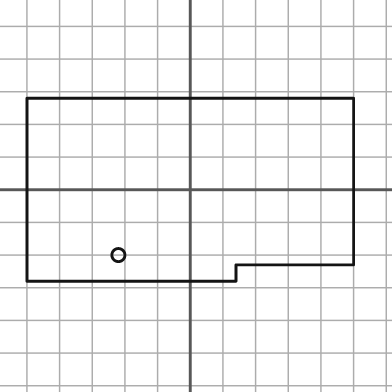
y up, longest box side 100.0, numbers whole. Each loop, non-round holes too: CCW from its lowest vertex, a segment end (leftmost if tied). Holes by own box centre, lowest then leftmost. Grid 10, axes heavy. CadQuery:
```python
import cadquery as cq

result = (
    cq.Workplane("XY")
    .moveTo(-50.0, -28.0)
    .lineTo(14.0, -28.0)
    .lineTo(14.0, -23.0)
    .lineTo(50.0, -23.0)
    .lineTo(50.0, 28.0)
    .lineTo(-50.0, 28.0)
    .close()
    .moveTo(-22.0, -20.0)
    .circle(2.0)
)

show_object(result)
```